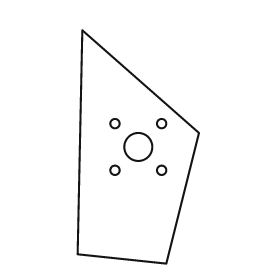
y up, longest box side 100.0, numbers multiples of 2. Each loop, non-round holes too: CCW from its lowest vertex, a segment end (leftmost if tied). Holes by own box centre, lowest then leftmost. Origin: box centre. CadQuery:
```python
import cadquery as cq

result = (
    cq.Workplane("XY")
    .moveTo(12.0, -50.0)
    .lineTo(26.0, 6.0)
    .lineTo(-24.0, 50.0)
    .lineTo(-26.0, -46.0)
    .close()
    .moveTo(-10.0, -10.0)
    .circle(2.0)
    .moveTo(10.0, -10.0)
    .circle(2.0)
    .moveTo(0.0, 0.0)
    .circle(6.0)
    .moveTo(-10.0, 10.0)
    .circle(2.0)
    .moveTo(10.0, 10.0)
    .circle(2.0)
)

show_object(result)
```